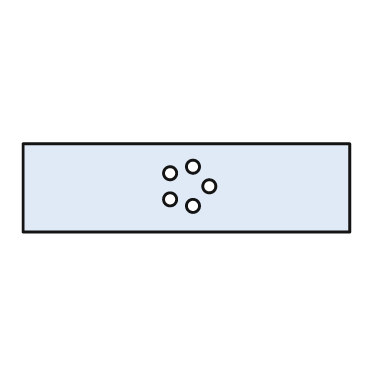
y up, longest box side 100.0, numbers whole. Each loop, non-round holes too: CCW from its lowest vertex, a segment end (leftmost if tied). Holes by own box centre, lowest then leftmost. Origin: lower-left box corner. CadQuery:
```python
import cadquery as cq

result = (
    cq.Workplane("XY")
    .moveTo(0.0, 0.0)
    .lineTo(100.0, 0.0)
    .lineTo(100.0, 27.0)
    .lineTo(0.0, 27.0)
    .close()
    .moveTo(52.0, 8.0)
    .circle(2.0)
    .moveTo(45.0, 10.0)
    .circle(2.0)
    .moveTo(57.0, 14.0)
    .circle(2.0)
    .moveTo(45.0, 18.0)
    .circle(2.0)
    .moveTo(52.0, 20.0)
    .circle(2.0)
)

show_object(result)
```